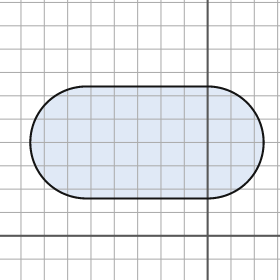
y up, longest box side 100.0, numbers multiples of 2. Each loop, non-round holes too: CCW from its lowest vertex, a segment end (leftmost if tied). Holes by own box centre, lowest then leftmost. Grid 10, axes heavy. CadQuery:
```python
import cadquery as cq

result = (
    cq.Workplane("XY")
    .moveTo(-52.0, 16.0)
    .lineTo(0.0, 16.0)
    .threePointArc((24.0, 40.0), (0.0, 64.0))
    .lineTo(-52.0, 64.0)
    .threePointArc((-76.0, 40.0), (-52.0, 16.0))
    .close()
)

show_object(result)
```